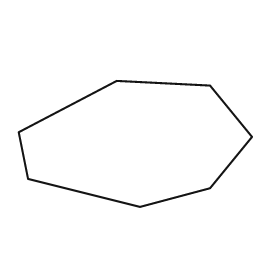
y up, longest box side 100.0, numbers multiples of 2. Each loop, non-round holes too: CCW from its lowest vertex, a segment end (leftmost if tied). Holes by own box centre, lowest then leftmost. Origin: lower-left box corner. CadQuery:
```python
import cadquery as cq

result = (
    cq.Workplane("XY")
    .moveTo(52.0, 0.0)
    .lineTo(82.0, 8.0)
    .lineTo(100.0, 30.0)
    .lineTo(82.0, 52.0)
    .lineTo(42.0, 54.0)
    .lineTo(0.0, 32.0)
    .lineTo(4.0, 12.0)
    .close()
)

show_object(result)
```